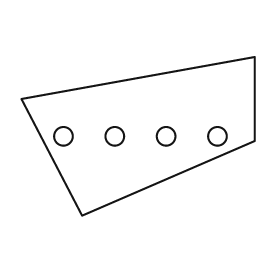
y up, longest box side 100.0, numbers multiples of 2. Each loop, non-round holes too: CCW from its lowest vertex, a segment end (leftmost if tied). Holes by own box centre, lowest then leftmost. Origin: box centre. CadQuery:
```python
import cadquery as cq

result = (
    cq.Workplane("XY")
    .moveTo(-24.0, -34.0)
    .lineTo(50.0, -2.0)
    .lineTo(50.0, 34.0)
    .lineTo(-50.0, 16.0)
    .close()
    .moveTo(-32.0, 0.0)
    .circle(4.0)
    .moveTo(-10.0, 0.0)
    .circle(4.0)
    .moveTo(12.0, 0.0)
    .circle(4.0)
    .moveTo(34.0, 0.0)
    .circle(4.0)
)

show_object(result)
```